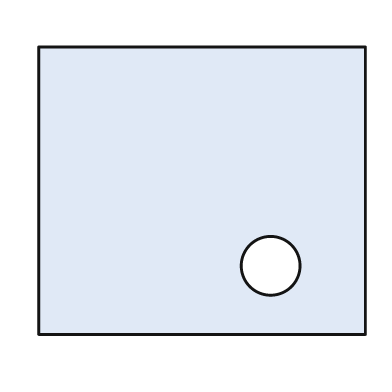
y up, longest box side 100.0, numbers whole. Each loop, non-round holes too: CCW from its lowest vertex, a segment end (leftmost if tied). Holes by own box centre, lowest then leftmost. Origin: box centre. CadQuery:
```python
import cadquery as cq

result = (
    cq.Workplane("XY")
    .moveTo(-50.0, -44.0)
    .lineTo(50.0, -44.0)
    .lineTo(50.0, 44.0)
    .lineTo(-50.0, 44.0)
    .close()
    .moveTo(21.0, -23.0)
    .circle(9.0)
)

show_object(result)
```